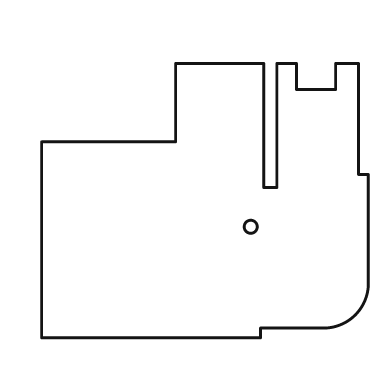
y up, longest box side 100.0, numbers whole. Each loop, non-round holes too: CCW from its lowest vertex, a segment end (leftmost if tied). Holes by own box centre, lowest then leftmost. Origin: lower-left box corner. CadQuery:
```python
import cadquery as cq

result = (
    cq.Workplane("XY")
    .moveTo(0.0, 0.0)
    .lineTo(67.0, 0.0)
    .lineTo(67.0, 3.0)
    .lineTo(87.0, 3.0)
    .threePointArc((96.0, 7.0), (100.0, 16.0))
    .lineTo(100.0, 50.0)
    .lineTo(97.0, 50.0)
    .lineTo(97.0, 84.0)
    .lineTo(90.0, 84.0)
    .lineTo(90.0, 76.0)
    .lineTo(78.0, 76.0)
    .lineTo(78.0, 84.0)
    .lineTo(72.0, 84.0)
    .lineTo(72.0, 46.0)
    .lineTo(68.0, 46.0)
    .lineTo(68.0, 84.0)
    .lineTo(41.0, 84.0)
    .lineTo(41.0, 60.0)
    .lineTo(0.0, 60.0)
    .close()
    .moveTo(64.0, 34.0)
    .circle(2.0)
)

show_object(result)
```